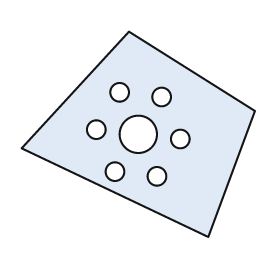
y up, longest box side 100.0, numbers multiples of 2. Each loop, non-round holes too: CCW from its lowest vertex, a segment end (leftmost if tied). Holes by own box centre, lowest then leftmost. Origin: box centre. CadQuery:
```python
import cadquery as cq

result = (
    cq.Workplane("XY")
    .moveTo(30.0, -44.0)
    .lineTo(50.0, 10.0)
    .lineTo(-4.0, 44.0)
    .lineTo(-50.0, -6.0)
    .close()
    .moveTo(8.0, -18.0)
    .circle(4.0)
    .moveTo(-10.0, -16.0)
    .circle(4.0)
    .moveTo(18.0, -2.0)
    .circle(4.0)
    .moveTo(0.0, 0.0)
    .circle(8.0)
    .moveTo(-18.0, 2.0)
    .circle(4.0)
    .moveTo(10.0, 16.0)
    .circle(4.0)
    .moveTo(-8.0, 18.0)
    .circle(4.0)
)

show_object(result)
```